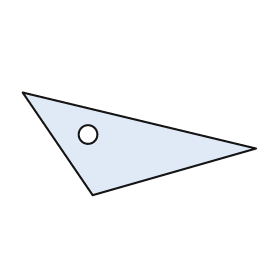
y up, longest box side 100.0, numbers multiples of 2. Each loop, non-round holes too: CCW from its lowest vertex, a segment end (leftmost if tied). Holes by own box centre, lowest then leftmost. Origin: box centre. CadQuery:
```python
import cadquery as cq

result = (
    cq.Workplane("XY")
    .moveTo(-20.0, -22.0)
    .lineTo(50.0, -2.0)
    .lineTo(-50.0, 22.0)
    .close()
    .moveTo(-22.0, 4.0)
    .circle(4.0)
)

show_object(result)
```